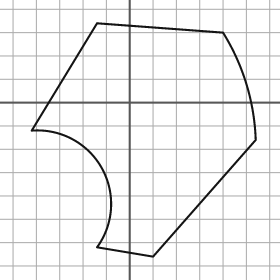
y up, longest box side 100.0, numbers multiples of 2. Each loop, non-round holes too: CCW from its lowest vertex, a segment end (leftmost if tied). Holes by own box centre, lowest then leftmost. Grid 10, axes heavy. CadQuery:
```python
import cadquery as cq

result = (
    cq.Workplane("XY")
    .moveTo(10.0, -66.0)
    .lineTo(54.0, -16.0)
    .threePointArc((50.0, 8.0), (40.0, 30.0))
    .lineTo(-14.0, 34.0)
    .lineTo(-42.0, -12.0)
    .threePointArc((-12.0, -28.0), (-14.0, -62.0))
    .close()
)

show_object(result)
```